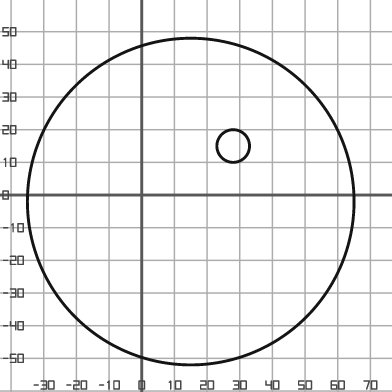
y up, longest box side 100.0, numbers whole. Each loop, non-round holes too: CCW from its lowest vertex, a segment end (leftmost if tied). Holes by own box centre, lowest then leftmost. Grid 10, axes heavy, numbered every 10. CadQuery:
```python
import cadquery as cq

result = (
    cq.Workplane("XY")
    .moveTo(15.0, -2.0)
    .circle(50.0)
    .moveTo(28.0, 15.0)
    .circle(5.0)
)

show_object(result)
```